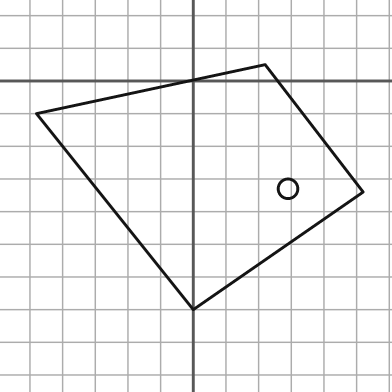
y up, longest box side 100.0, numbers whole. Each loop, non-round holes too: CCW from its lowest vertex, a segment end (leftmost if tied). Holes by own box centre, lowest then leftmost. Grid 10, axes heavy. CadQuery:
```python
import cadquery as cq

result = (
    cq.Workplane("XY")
    .moveTo(0.0, -70.0)
    .lineTo(52.0, -34.0)
    .lineTo(22.0, 5.0)
    .lineTo(-48.0, -10.0)
    .close()
    .moveTo(29.0, -33.0)
    .circle(3.0)
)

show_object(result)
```